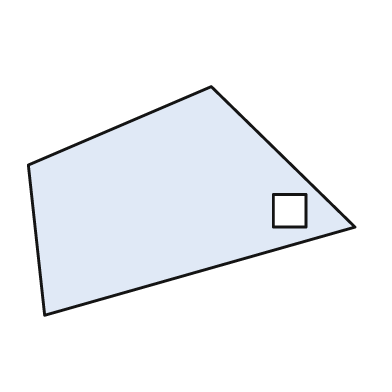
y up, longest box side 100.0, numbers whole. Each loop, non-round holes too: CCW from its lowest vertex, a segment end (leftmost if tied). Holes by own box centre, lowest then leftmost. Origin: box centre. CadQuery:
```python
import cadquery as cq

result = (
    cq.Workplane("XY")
    .moveTo(-45.0, -35.0)
    .lineTo(50.0, -8.0)
    .lineTo(6.0, 35.0)
    .lineTo(-50.0, 11.0)
    .close()
    .moveTo(25.0, -8.0)
    .lineTo(35.0, -8.0)
    .lineTo(35.0, 2.0)
    .lineTo(25.0, 2.0)
    .close()
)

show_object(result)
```